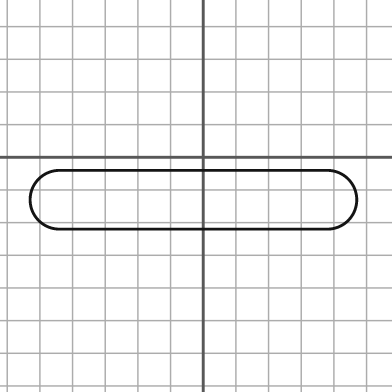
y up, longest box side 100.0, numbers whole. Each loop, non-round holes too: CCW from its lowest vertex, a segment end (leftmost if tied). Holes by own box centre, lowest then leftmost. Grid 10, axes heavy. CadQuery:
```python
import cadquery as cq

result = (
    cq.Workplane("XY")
    .moveTo(-44.0, -22.0)
    .lineTo(38.0, -22.0)
    .threePointArc((47.0, -13.0), (38.0, -4.0))
    .lineTo(-44.0, -4.0)
    .threePointArc((-53.0, -13.0), (-44.0, -22.0))
    .close()
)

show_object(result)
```